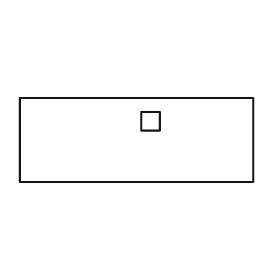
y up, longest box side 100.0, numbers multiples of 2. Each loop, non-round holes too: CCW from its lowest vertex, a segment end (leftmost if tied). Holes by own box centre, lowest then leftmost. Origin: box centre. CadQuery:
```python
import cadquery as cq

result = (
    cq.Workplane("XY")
    .moveTo(-50.0, -18.0)
    .lineTo(50.0, -18.0)
    .lineTo(50.0, 18.0)
    .lineTo(-50.0, 18.0)
    .close()
    .moveTo(2.0, 4.0)
    .lineTo(10.0, 4.0)
    .lineTo(10.0, 12.0)
    .lineTo(2.0, 12.0)
    .close()
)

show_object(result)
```